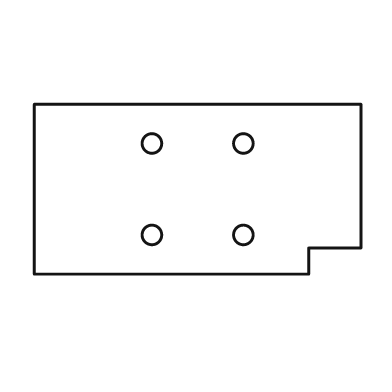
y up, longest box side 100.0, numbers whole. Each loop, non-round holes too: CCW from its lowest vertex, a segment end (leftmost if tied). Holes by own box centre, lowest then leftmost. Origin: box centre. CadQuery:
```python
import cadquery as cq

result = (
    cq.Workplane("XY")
    .moveTo(-50.0, -26.0)
    .lineTo(34.0, -26.0)
    .lineTo(34.0, -18.0)
    .lineTo(50.0, -18.0)
    .lineTo(50.0, 26.0)
    .lineTo(-50.0, 26.0)
    .close()
    .moveTo(-14.0, -14.0)
    .circle(3.0)
    .moveTo(14.0, -14.0)
    .circle(3.0)
    .moveTo(-14.0, 14.0)
    .circle(3.0)
    .moveTo(14.0, 14.0)
    .circle(3.0)
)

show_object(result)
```